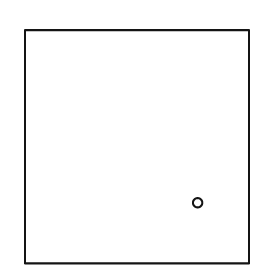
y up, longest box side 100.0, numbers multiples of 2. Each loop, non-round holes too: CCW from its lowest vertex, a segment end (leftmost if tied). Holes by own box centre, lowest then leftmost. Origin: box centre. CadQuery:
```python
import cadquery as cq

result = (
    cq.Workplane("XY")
    .moveTo(-48.0, -50.0)
    .lineTo(48.0, -50.0)
    .lineTo(48.0, 50.0)
    .lineTo(-48.0, 50.0)
    .close()
    .moveTo(26.0, -24.0)
    .circle(2.0)
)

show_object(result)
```